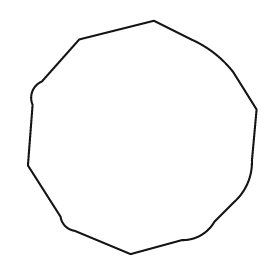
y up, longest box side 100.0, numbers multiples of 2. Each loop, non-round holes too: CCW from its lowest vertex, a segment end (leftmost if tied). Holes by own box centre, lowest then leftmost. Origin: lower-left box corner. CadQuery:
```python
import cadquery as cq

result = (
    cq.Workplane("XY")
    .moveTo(44.0, 0.0)
    .lineTo(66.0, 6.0)
    .threePointArc((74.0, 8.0), (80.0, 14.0))
    .lineTo(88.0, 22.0)
    .threePointArc((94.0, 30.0), (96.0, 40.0))
    .lineTo(98.0, 62.0)
    .lineTo(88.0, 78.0)
    .threePointArc((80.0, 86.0), (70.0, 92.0))
    .lineTo(54.0, 100.0)
    .lineTo(22.0, 92.0)
    .lineTo(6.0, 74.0)
    .threePointArc((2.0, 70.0), (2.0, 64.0))
    .lineTo(0.0, 38.0)
    .lineTo(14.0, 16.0)
    .threePointArc((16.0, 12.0), (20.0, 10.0))
    .close()
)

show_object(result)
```